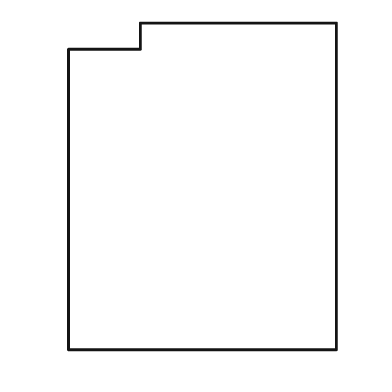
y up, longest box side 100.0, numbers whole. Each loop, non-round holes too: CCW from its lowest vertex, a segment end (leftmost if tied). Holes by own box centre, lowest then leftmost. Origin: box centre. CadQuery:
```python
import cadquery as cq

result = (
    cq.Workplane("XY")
    .moveTo(-41.0, -50.0)
    .lineTo(41.0, -50.0)
    .lineTo(41.0, 50.0)
    .lineTo(-19.0, 50.0)
    .lineTo(-19.0, 42.0)
    .lineTo(-41.0, 42.0)
    .close()
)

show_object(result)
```